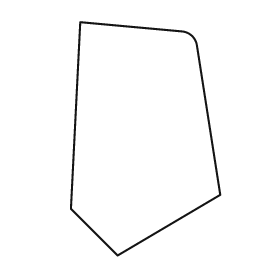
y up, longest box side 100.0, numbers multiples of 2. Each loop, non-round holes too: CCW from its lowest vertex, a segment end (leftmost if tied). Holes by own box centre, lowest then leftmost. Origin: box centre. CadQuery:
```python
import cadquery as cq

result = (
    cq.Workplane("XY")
    .moveTo(-12.0, -50.0)
    .lineTo(32.0, -24.0)
    .lineTo(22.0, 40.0)
    .threePointArc((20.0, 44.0), (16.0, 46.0))
    .lineTo(-28.0, 50.0)
    .lineTo(-32.0, -30.0)
    .close()
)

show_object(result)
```